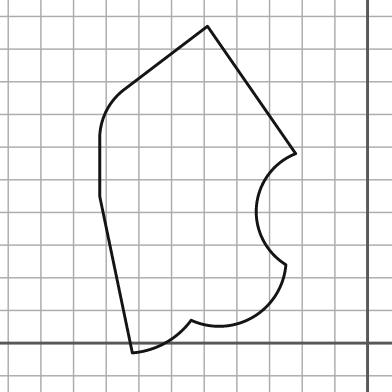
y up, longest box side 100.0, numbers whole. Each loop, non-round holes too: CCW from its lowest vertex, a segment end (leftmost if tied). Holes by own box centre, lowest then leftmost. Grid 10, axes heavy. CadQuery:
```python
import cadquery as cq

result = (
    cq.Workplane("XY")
    .moveTo(-72.0, -3.0)
    .threePointArc((-62.0, 0.0), (-54.0, 7.0))
    .threePointArc((-35.0, 8.0), (-25.0, 24.0))
    .threePointArc((-34.0, 42.0), (-22.0, 58.0))
    .lineTo(-49.0, 97.0)
    .lineTo(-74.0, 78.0)
    .threePointArc((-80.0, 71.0), (-82.0, 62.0))
    .lineTo(-82.0, 45.0)
    .close()
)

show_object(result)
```